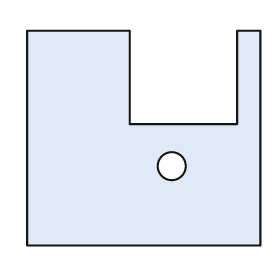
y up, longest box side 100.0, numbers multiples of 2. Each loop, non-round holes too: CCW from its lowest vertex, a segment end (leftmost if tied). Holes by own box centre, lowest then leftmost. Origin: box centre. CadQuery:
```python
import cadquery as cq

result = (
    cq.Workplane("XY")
    .moveTo(-50.0, -46.0)
    .lineTo(50.0, -46.0)
    .lineTo(50.0, 46.0)
    .lineTo(40.0, 46.0)
    .lineTo(40.0, 6.0)
    .lineTo(-6.0, 6.0)
    .lineTo(-6.0, 46.0)
    .lineTo(-50.0, 46.0)
    .close()
    .moveTo(12.0, -12.0)
    .circle(6.0)
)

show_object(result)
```